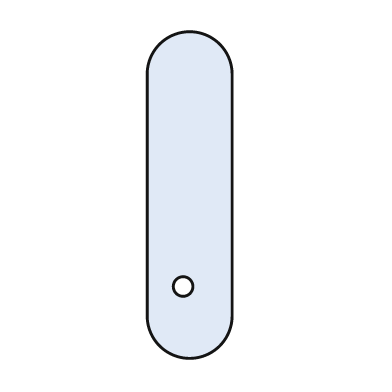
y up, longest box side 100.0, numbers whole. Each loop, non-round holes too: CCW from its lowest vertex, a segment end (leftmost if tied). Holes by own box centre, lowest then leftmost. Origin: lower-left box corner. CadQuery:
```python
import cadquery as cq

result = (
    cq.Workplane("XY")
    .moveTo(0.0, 13.0)
    .threePointArc((13.0, 0.0), (26.0, 13.0))
    .lineTo(26.0, 87.0)
    .threePointArc((13.0, 100.0), (0.0, 87.0))
    .close()
    .moveTo(11.0, 22.0)
    .circle(3.0)
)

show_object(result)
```